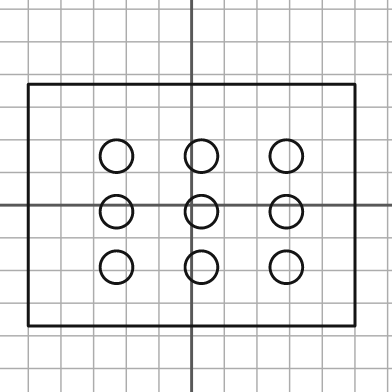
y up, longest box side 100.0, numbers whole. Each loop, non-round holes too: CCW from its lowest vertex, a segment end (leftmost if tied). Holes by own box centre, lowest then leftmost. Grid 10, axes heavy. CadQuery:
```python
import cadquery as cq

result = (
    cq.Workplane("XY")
    .moveTo(-50.0, -37.0)
    .lineTo(50.0, -37.0)
    .lineTo(50.0, 37.0)
    .lineTo(-50.0, 37.0)
    .close()
    .moveTo(-23.0, -19.0)
    .circle(5.0)
    .moveTo(3.0, -19.0)
    .circle(5.0)
    .moveTo(29.0, -19.0)
    .circle(5.0)
    .moveTo(-23.0, -2.0)
    .circle(5.0)
    .moveTo(3.0, -2.0)
    .circle(5.0)
    .moveTo(29.0, -2.0)
    .circle(5.0)
    .moveTo(-23.0, 15.0)
    .circle(5.0)
    .moveTo(3.0, 15.0)
    .circle(5.0)
    .moveTo(29.0, 15.0)
    .circle(5.0)
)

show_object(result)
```